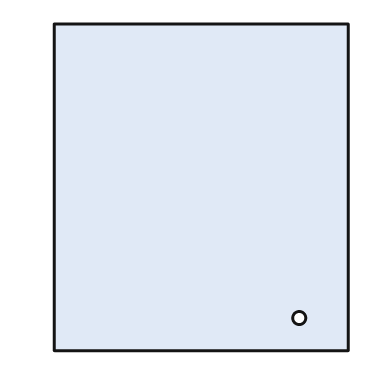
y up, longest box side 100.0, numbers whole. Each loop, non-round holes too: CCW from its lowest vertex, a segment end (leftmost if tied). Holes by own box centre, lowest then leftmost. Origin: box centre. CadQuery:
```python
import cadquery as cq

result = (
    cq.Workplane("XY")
    .moveTo(-45.0, -50.0)
    .lineTo(45.0, -50.0)
    .lineTo(45.0, 50.0)
    .lineTo(-45.0, 50.0)
    .close()
    .moveTo(30.0, -40.0)
    .circle(2.0)
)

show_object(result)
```